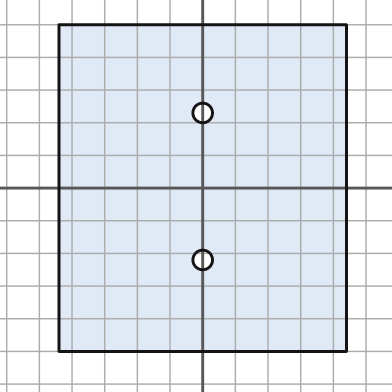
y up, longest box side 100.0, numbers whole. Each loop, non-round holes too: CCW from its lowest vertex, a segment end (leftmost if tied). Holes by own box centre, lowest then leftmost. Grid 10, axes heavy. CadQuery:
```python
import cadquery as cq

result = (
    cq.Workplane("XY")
    .moveTo(-44.0, -50.0)
    .lineTo(44.0, -50.0)
    .lineTo(44.0, 50.0)
    .lineTo(-44.0, 50.0)
    .close()
    .moveTo(0.0, -22.0)
    .circle(3.0)
    .moveTo(0.0, 23.0)
    .circle(3.0)
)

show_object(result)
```